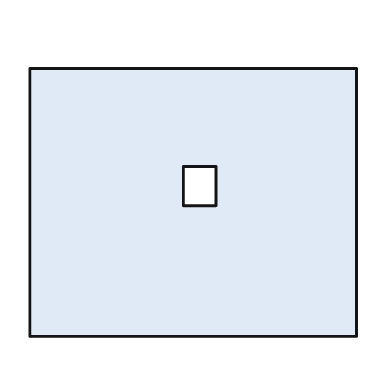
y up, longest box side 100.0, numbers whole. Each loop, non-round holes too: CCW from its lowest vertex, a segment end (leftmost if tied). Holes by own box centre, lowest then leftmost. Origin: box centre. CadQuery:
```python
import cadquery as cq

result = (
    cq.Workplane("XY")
    .moveTo(-50.0, -41.0)
    .lineTo(50.0, -41.0)
    .lineTo(50.0, 41.0)
    .lineTo(-50.0, 41.0)
    .close()
    .moveTo(-3.0, -1.0)
    .lineTo(7.0, -1.0)
    .lineTo(7.0, 11.0)
    .lineTo(-3.0, 11.0)
    .close()
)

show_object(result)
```